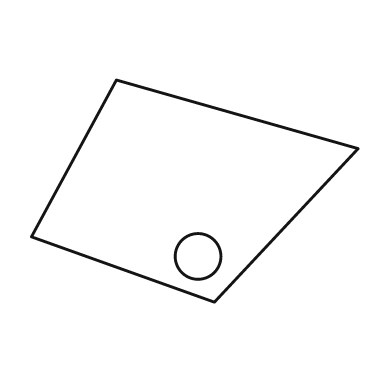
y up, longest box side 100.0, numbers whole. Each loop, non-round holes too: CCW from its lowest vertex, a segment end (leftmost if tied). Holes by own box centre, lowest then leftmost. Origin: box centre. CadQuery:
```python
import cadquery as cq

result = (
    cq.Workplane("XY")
    .moveTo(6.0, -34.0)
    .lineTo(50.0, 13.0)
    .lineTo(-24.0, 34.0)
    .lineTo(-50.0, -14.0)
    .close()
    .moveTo(1.0, -20.0)
    .circle(7.0)
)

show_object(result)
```